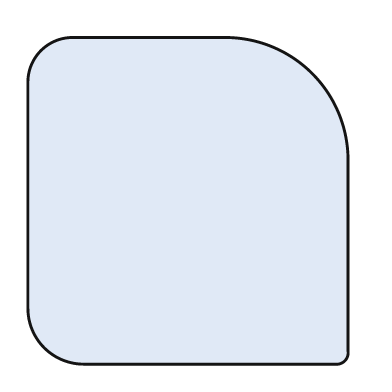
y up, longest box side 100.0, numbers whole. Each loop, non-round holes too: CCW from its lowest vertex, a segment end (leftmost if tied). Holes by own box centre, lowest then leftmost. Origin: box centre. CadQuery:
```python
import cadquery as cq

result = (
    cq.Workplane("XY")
    .moveTo(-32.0, -50.0)
    .lineTo(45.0, -50.0)
    .threePointArc((48.0, -49.0), (49.0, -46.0))
    .lineTo(49.0, 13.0)
    .threePointArc((38.0, 39.0), (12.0, 50.0))
    .lineTo(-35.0, 50.0)
    .threePointArc((-45.0, 46.0), (-49.0, 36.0))
    .lineTo(-49.0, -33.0)
    .threePointArc((-44.0, -45.0), (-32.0, -50.0))
    .close()
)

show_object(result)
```